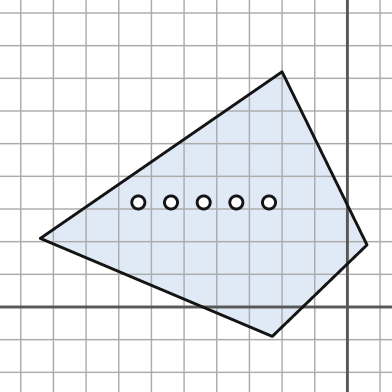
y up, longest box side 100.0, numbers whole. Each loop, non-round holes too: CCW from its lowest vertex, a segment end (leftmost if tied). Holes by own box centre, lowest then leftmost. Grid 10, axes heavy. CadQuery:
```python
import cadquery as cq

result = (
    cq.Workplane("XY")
    .moveTo(-23.0, -9.0)
    .lineTo(6.0, 19.0)
    .lineTo(-20.0, 72.0)
    .lineTo(-94.0, 21.0)
    .close()
    .moveTo(-64.0, 32.0)
    .circle(2.0)
    .moveTo(-54.0, 32.0)
    .circle(2.0)
    .moveTo(-44.0, 32.0)
    .circle(2.0)
    .moveTo(-34.0, 32.0)
    .circle(2.0)
    .moveTo(-24.0, 32.0)
    .circle(2.0)
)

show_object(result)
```